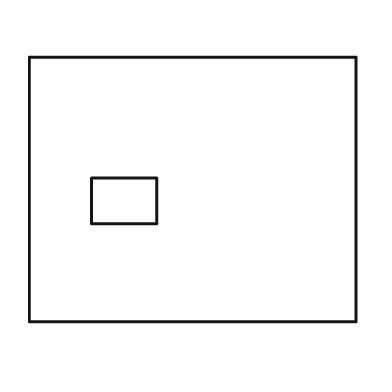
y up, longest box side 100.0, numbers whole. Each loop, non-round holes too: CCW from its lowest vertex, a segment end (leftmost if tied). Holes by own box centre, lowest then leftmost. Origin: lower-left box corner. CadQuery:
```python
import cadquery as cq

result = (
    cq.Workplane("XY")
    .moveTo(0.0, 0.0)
    .lineTo(100.0, 0.0)
    .lineTo(100.0, 81.0)
    .lineTo(0.0, 81.0)
    .close()
    .moveTo(19.0, 30.0)
    .lineTo(39.0, 30.0)
    .lineTo(39.0, 44.0)
    .lineTo(19.0, 44.0)
    .close()
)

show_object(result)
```